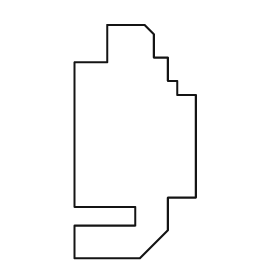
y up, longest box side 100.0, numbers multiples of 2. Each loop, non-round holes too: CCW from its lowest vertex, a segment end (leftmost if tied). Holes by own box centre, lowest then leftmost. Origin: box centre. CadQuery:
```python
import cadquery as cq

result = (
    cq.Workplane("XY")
    .moveTo(-26.0, -50.0)
    .lineTo(2.0, -50.0)
    .lineTo(14.0, -38.0)
    .lineTo(14.0, -24.0)
    .lineTo(26.0, -24.0)
    .lineTo(26.0, 20.0)
    .lineTo(18.0, 20.0)
    .lineTo(18.0, 26.0)
    .lineTo(14.0, 26.0)
    .lineTo(14.0, 36.0)
    .lineTo(8.0, 36.0)
    .lineTo(8.0, 46.0)
    .lineTo(4.0, 50.0)
    .lineTo(-12.0, 50.0)
    .lineTo(-12.0, 34.0)
    .lineTo(-26.0, 34.0)
    .lineTo(-26.0, -28.0)
    .lineTo(0.0, -28.0)
    .lineTo(0.0, -36.0)
    .lineTo(-26.0, -36.0)
    .close()
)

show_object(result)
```